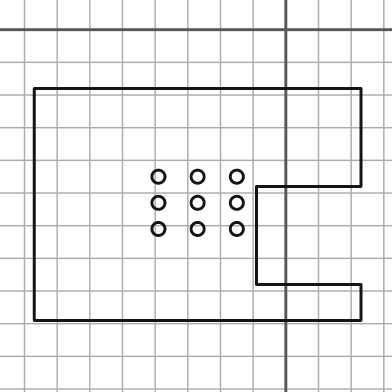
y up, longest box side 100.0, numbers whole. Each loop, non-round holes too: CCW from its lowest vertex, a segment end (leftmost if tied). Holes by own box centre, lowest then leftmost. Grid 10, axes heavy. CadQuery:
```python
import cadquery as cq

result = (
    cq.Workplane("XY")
    .moveTo(-77.0, -89.0)
    .lineTo(23.0, -89.0)
    .lineTo(23.0, -78.0)
    .lineTo(-9.0, -78.0)
    .lineTo(-9.0, -48.0)
    .lineTo(23.0, -48.0)
    .lineTo(23.0, -18.0)
    .lineTo(-77.0, -18.0)
    .close()
    .moveTo(-39.0, -61.0)
    .circle(2.0)
    .moveTo(-27.0, -61.0)
    .circle(2.0)
    .moveTo(-15.0, -61.0)
    .circle(2.0)
    .moveTo(-39.0, -53.0)
    .circle(2.0)
    .moveTo(-27.0, -53.0)
    .circle(2.0)
    .moveTo(-15.0, -53.0)
    .circle(2.0)
    .moveTo(-39.0, -45.0)
    .circle(2.0)
    .moveTo(-27.0, -45.0)
    .circle(2.0)
    .moveTo(-15.0, -45.0)
    .circle(2.0)
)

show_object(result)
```